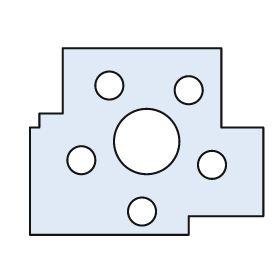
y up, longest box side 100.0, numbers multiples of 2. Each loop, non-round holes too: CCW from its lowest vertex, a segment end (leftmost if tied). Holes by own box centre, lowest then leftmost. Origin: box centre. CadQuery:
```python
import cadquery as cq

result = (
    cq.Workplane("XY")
    .moveTo(-50.0, -40.0)
    .lineTo(18.0, -40.0)
    .lineTo(18.0, -32.0)
    .lineTo(50.0, -32.0)
    .lineTo(50.0, 6.0)
    .lineTo(32.0, 6.0)
    .lineTo(32.0, 40.0)
    .lineTo(-36.0, 40.0)
    .lineTo(-36.0, 12.0)
    .lineTo(-46.0, 12.0)
    .lineTo(-46.0, 6.0)
    .lineTo(-50.0, 6.0)
    .close()
    .moveTo(-2.0, -30.0)
    .circle(6.0)
    .moveTo(28.0, -10.0)
    .circle(6.0)
    .moveTo(-28.0, -8.0)
    .circle(6.0)
    .moveTo(0.0, 0.0)
    .circle(14.0)
    .moveTo(18.0, 22.0)
    .circle(6.0)
    .moveTo(-16.0, 24.0)
    .circle(6.0)
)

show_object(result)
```